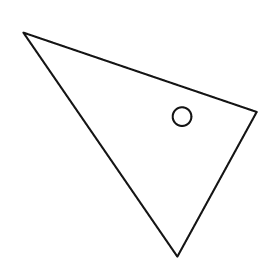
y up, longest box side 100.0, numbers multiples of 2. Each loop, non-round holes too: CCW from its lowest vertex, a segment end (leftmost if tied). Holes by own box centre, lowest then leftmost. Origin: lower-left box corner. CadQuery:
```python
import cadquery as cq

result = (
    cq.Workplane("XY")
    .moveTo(66.0, 0.0)
    .lineTo(100.0, 62.0)
    .lineTo(0.0, 96.0)
    .close()
    .moveTo(68.0, 60.0)
    .circle(4.0)
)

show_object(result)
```